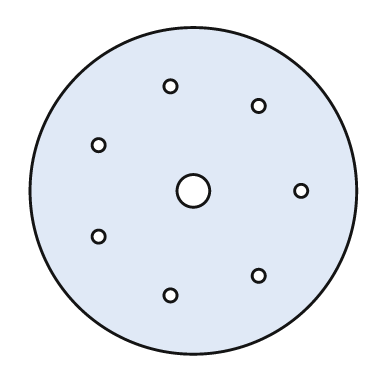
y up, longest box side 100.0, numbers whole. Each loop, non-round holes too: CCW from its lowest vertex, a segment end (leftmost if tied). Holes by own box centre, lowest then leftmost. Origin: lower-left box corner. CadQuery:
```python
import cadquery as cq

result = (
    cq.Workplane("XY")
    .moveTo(50.0, 50.0)
    .circle(50.0)
    .moveTo(43.0, 18.0)
    .circle(2.0)
    .moveTo(70.0, 24.0)
    .circle(2.0)
    .moveTo(21.0, 36.0)
    .circle(2.0)
    .moveTo(50.0, 50.0)
    .circle(5.0)
    .moveTo(83.0, 50.0)
    .circle(2.0)
    .moveTo(21.0, 64.0)
    .circle(2.0)
    .moveTo(70.0, 76.0)
    .circle(2.0)
    .moveTo(43.0, 82.0)
    .circle(2.0)
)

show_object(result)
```